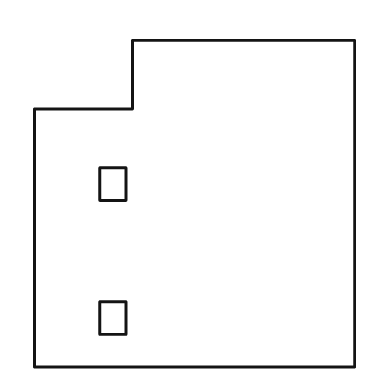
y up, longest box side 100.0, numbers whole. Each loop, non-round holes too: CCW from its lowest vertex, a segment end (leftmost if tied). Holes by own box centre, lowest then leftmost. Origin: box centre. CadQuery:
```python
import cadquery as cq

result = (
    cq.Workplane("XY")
    .moveTo(-49.0, -50.0)
    .lineTo(49.0, -50.0)
    .lineTo(49.0, 50.0)
    .lineTo(-19.0, 50.0)
    .lineTo(-19.0, 29.0)
    .lineTo(-49.0, 29.0)
    .close()
    .moveTo(-29.0, -40.0)
    .lineTo(-21.0, -40.0)
    .lineTo(-21.0, -30.0)
    .lineTo(-29.0, -30.0)
    .close()
    .moveTo(-29.0, 1.0)
    .lineTo(-21.0, 1.0)
    .lineTo(-21.0, 11.0)
    .lineTo(-29.0, 11.0)
    .close()
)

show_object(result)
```